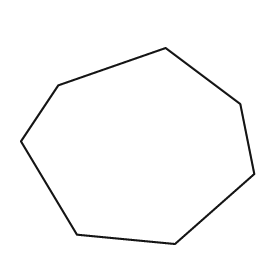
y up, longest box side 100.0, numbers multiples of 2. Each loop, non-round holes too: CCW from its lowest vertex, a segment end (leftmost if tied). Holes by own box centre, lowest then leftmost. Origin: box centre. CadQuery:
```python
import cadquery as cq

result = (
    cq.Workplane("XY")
    .moveTo(16.0, -42.0)
    .lineTo(50.0, -12.0)
    .lineTo(44.0, 18.0)
    .lineTo(12.0, 42.0)
    .lineTo(-34.0, 26.0)
    .lineTo(-50.0, 2.0)
    .lineTo(-26.0, -38.0)
    .close()
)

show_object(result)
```